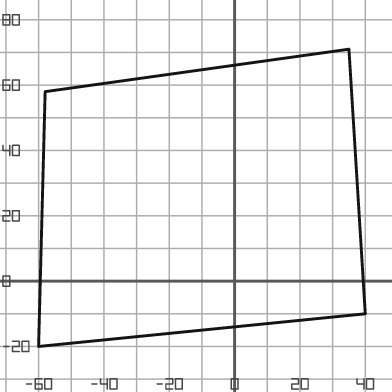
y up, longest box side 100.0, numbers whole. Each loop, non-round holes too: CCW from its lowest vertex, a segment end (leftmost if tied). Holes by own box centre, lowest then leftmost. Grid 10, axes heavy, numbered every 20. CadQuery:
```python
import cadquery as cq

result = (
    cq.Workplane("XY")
    .moveTo(-60.0, -20.0)
    .lineTo(40.0, -10.0)
    .lineTo(35.0, 71.0)
    .lineTo(-58.0, 58.0)
    .close()
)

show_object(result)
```